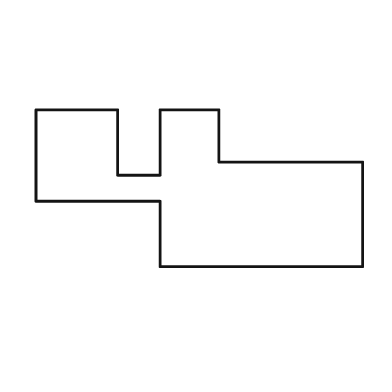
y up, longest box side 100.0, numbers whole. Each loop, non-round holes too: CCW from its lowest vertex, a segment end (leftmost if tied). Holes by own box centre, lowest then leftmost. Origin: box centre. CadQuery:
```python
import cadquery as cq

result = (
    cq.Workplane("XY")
    .moveTo(-12.0, -24.0)
    .lineTo(50.0, -24.0)
    .lineTo(50.0, 8.0)
    .lineTo(6.0, 8.0)
    .lineTo(6.0, 24.0)
    .lineTo(-12.0, 24.0)
    .lineTo(-12.0, 4.0)
    .lineTo(-25.0, 4.0)
    .lineTo(-25.0, 24.0)
    .lineTo(-50.0, 24.0)
    .lineTo(-50.0, -4.0)
    .lineTo(-12.0, -4.0)
    .close()
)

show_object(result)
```